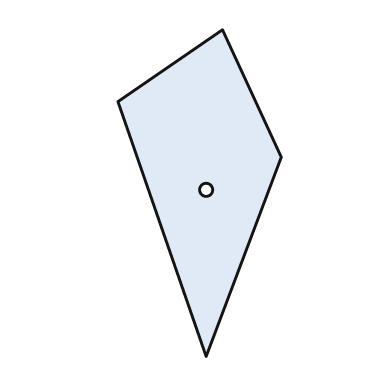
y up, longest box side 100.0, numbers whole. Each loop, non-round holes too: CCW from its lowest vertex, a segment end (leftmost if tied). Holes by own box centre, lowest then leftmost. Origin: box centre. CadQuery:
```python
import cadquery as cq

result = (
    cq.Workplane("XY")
    .moveTo(2.0, -50.0)
    .lineTo(25.0, 11.0)
    .lineTo(7.0, 50.0)
    .lineTo(-25.0, 28.0)
    .close()
    .moveTo(2.0, 1.0)
    .circle(2.0)
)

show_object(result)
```